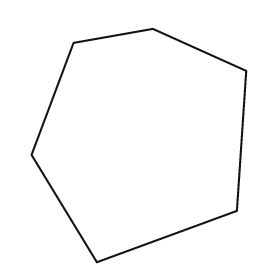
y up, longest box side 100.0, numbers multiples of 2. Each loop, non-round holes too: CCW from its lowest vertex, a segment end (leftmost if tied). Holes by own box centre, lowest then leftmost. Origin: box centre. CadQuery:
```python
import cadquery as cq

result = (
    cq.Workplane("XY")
    .moveTo(-18.0, -50.0)
    .lineTo(42.0, -28.0)
    .lineTo(46.0, 32.0)
    .lineTo(6.0, 50.0)
    .lineTo(-28.0, 44.0)
    .lineTo(-46.0, -4.0)
    .close()
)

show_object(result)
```